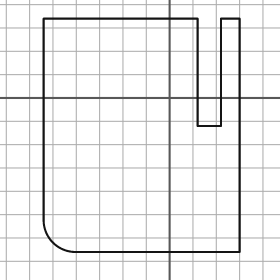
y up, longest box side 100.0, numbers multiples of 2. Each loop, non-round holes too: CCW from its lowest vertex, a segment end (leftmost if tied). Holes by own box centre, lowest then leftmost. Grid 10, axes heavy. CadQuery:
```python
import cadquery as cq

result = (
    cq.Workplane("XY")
    .moveTo(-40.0, -66.0)
    .lineTo(30.0, -66.0)
    .lineTo(30.0, 34.0)
    .lineTo(22.0, 34.0)
    .lineTo(22.0, -12.0)
    .lineTo(12.0, -12.0)
    .lineTo(12.0, 34.0)
    .lineTo(-54.0, 34.0)
    .lineTo(-54.0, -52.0)
    .threePointArc((-50.0, -62.0), (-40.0, -66.0))
    .close()
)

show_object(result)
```